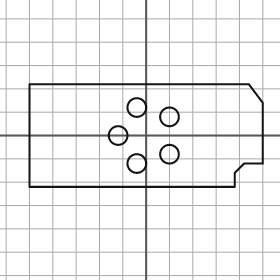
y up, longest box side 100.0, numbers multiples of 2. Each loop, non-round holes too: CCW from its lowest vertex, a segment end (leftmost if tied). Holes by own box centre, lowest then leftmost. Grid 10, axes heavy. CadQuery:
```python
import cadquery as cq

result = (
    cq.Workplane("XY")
    .moveTo(-50.0, -22.0)
    .lineTo(38.0, -22.0)
    .lineTo(38.0, -16.0)
    .lineTo(42.0, -12.0)
    .lineTo(50.0, -12.0)
    .lineTo(50.0, 14.0)
    .lineTo(44.0, 22.0)
    .lineTo(-50.0, 22.0)
    .close()
    .moveTo(-4.0, -12.0)
    .circle(4.0)
    .moveTo(10.0, -8.0)
    .circle(4.0)
    .moveTo(-12.0, 0.0)
    .circle(4.0)
    .moveTo(10.0, 8.0)
    .circle(4.0)
    .moveTo(-4.0, 12.0)
    .circle(4.0)
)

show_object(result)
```